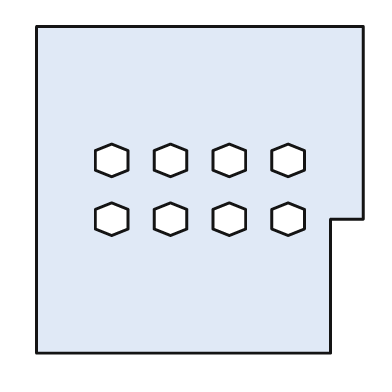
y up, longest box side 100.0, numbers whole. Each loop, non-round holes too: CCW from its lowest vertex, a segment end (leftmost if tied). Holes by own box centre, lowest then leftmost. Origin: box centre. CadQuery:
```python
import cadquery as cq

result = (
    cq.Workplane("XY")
    .moveTo(-50.0, -50.0)
    .lineTo(40.0, -50.0)
    .lineTo(40.0, -9.0)
    .lineTo(50.0, -9.0)
    .lineTo(50.0, 50.0)
    .lineTo(-50.0, 50.0)
    .close()
    .moveTo(-27.0, -14.0)
    .lineTo(-22.0, -12.0)
    .lineTo(-22.0, -6.0)
    .lineTo(-27.0, -4.0)
    .lineTo(-32.0, -6.0)
    .lineTo(-32.0, -12.0)
    .close()
    .moveTo(-9.0, -14.0)
    .lineTo(-4.0, -12.0)
    .lineTo(-4.0, -6.0)
    .lineTo(-9.0, -4.0)
    .lineTo(-14.0, -6.0)
    .lineTo(-14.0, -12.0)
    .close()
    .moveTo(9.0, -14.0)
    .lineTo(14.0, -12.0)
    .lineTo(14.0, -6.0)
    .lineTo(9.0, -4.0)
    .lineTo(4.0, -6.0)
    .lineTo(4.0, -12.0)
    .close()
    .moveTo(27.0, -14.0)
    .lineTo(32.0, -12.0)
    .lineTo(32.0, -6.0)
    .lineTo(27.0, -4.0)
    .lineTo(22.0, -6.0)
    .lineTo(22.0, -12.0)
    .close()
    .moveTo(-27.0, 4.0)
    .lineTo(-22.0, 6.0)
    .lineTo(-22.0, 12.0)
    .lineTo(-27.0, 14.0)
    .lineTo(-32.0, 12.0)
    .lineTo(-32.0, 6.0)
    .close()
    .moveTo(-9.0, 4.0)
    .lineTo(-4.0, 6.0)
    .lineTo(-4.0, 12.0)
    .lineTo(-9.0, 14.0)
    .lineTo(-14.0, 12.0)
    .lineTo(-14.0, 6.0)
    .close()
    .moveTo(9.0, 4.0)
    .lineTo(14.0, 6.0)
    .lineTo(14.0, 12.0)
    .lineTo(9.0, 14.0)
    .lineTo(4.0, 12.0)
    .lineTo(4.0, 6.0)
    .close()
    .moveTo(27.0, 4.0)
    .lineTo(32.0, 6.0)
    .lineTo(32.0, 12.0)
    .lineTo(27.0, 14.0)
    .lineTo(22.0, 12.0)
    .lineTo(22.0, 6.0)
    .close()
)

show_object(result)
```